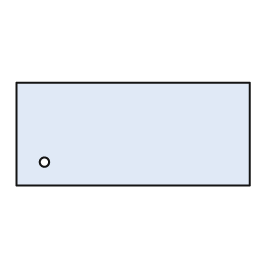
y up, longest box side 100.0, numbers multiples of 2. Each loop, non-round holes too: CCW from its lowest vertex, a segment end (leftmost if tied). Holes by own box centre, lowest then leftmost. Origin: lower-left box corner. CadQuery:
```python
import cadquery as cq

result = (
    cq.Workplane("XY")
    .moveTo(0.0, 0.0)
    .lineTo(100.0, 0.0)
    .lineTo(100.0, 44.0)
    .lineTo(0.0, 44.0)
    .close()
    .moveTo(12.0, 10.0)
    .circle(2.0)
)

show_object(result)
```